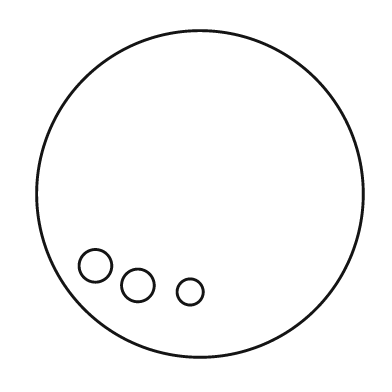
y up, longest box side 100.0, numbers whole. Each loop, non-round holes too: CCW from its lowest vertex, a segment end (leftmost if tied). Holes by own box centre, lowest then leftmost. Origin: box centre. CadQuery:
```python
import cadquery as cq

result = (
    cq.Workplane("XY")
    .moveTo(0.0, 0.0)
    .circle(50.0)
    .moveTo(-3.0, -30.0)
    .circle(4.0)
    .moveTo(-19.0, -28.0)
    .circle(5.0)
    .moveTo(-32.0, -22.0)
    .circle(5.0)
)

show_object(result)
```